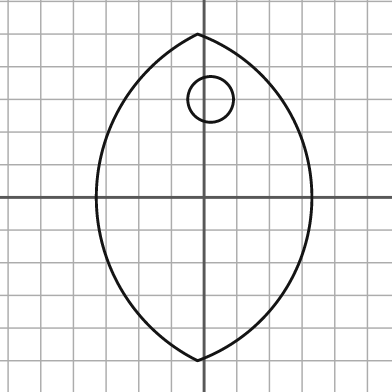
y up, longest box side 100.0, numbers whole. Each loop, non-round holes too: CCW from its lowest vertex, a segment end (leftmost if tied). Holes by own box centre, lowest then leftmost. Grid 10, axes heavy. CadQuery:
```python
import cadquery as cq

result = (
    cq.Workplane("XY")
    .moveTo(-2.0, -50.0)
    .threePointArc((33.0, 0.0), (-2.0, 50.0))
    .threePointArc((-33.0, 0.0), (-2.0, -50.0))
    .close()
    .moveTo(2.0, 30.0)
    .circle(7.0)
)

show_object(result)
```